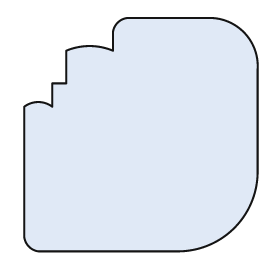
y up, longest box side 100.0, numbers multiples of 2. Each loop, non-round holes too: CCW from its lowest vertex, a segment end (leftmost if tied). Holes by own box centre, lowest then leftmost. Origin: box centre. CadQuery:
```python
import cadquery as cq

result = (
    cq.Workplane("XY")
    .moveTo(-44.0, -50.0)
    .lineTo(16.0, -50.0)
    .threePointArc((40.0, -40.0), (50.0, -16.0))
    .lineTo(50.0, 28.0)
    .threePointArc((44.0, 44.0), (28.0, 50.0))
    .lineTo(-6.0, 50.0)
    .threePointArc((-10.0, 48.0), (-12.0, 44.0))
    .lineTo(-12.0, 36.0)
    .threePointArc((-22.0, 38.0), (-32.0, 36.0))
    .lineTo(-32.0, 22.0)
    .lineTo(-38.0, 22.0)
    .lineTo(-38.0, 12.0)
    .threePointArc((-44.0, 14.0), (-50.0, 12.0))
    .lineTo(-50.0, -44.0)
    .threePointArc((-48.0, -48.0), (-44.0, -50.0))
    .close()
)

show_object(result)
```